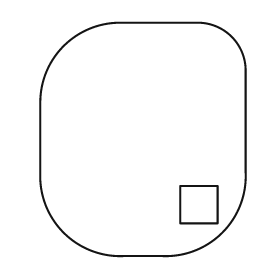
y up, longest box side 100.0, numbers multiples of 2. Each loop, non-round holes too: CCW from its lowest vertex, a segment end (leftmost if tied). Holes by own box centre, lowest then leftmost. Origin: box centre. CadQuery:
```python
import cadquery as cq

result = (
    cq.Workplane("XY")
    .moveTo(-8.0, -50.0)
    .lineTo(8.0, -50.0)
    .threePointArc((34.0, -40.0), (44.0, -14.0))
    .lineTo(44.0, 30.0)
    .threePointArc((38.0, 44.0), (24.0, 50.0))
    .lineTo(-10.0, 50.0)
    .threePointArc((-34.0, 40.0), (-44.0, 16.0))
    .lineTo(-44.0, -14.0)
    .threePointArc((-34.0, -40.0), (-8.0, -50.0))
    .close()
    .moveTo(16.0, -36.0)
    .lineTo(32.0, -36.0)
    .lineTo(32.0, -20.0)
    .lineTo(16.0, -20.0)
    .close()
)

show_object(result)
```